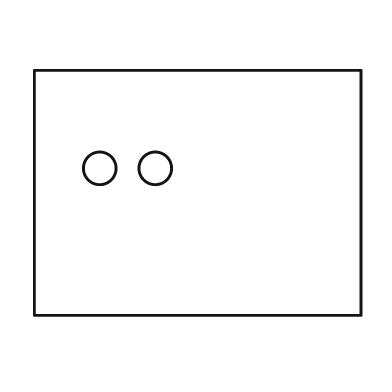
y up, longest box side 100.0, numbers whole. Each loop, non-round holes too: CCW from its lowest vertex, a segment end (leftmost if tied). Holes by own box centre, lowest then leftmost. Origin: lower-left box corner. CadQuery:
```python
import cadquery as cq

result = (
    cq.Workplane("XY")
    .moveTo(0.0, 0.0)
    .lineTo(100.0, 0.0)
    .lineTo(100.0, 75.0)
    .lineTo(0.0, 75.0)
    .close()
    .moveTo(20.0, 45.0)
    .circle(5.0)
    .moveTo(37.0, 45.0)
    .circle(5.0)
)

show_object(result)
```